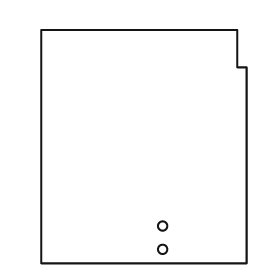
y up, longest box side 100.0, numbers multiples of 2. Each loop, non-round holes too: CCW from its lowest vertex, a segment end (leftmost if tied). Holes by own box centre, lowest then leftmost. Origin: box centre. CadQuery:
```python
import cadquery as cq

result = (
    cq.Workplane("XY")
    .moveTo(-44.0, -50.0)
    .lineTo(44.0, -50.0)
    .lineTo(44.0, 34.0)
    .lineTo(40.0, 34.0)
    .lineTo(40.0, 50.0)
    .lineTo(-44.0, 50.0)
    .close()
    .moveTo(8.0, -44.0)
    .circle(2.0)
    .moveTo(8.0, -34.0)
    .circle(2.0)
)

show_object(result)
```